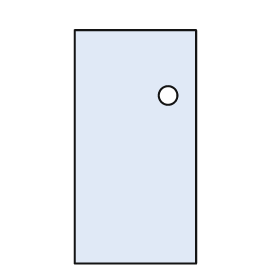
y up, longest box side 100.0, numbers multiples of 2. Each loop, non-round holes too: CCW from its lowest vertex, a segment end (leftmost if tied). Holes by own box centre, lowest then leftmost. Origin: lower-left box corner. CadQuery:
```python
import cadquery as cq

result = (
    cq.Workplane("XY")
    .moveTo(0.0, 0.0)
    .lineTo(52.0, 0.0)
    .lineTo(52.0, 100.0)
    .lineTo(0.0, 100.0)
    .close()
    .moveTo(40.0, 72.0)
    .circle(4.0)
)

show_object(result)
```